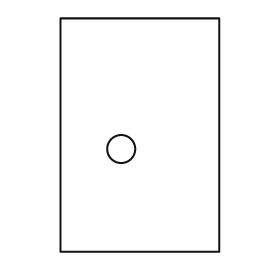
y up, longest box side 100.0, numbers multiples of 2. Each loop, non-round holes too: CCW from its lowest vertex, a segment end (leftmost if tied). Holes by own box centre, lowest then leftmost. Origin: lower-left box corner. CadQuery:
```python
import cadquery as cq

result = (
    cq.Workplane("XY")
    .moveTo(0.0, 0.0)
    .lineTo(68.0, 0.0)
    .lineTo(68.0, 100.0)
    .lineTo(0.0, 100.0)
    .close()
    .moveTo(26.0, 44.0)
    .circle(6.0)
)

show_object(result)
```